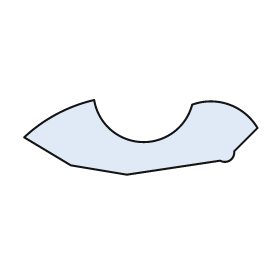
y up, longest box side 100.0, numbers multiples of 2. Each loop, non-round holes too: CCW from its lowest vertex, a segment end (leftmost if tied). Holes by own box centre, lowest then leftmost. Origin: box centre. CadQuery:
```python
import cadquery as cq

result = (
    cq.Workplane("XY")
    .moveTo(-6.0, -16.0)
    .lineTo(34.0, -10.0)
    .threePointArc((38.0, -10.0), (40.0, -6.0))
    .lineTo(50.0, 4.0)
    .threePointArc((38.0, 14.0), (22.0, 14.0))
    .threePointArc((0.0, -2.0), (-20.0, 16.0))
    .threePointArc((-36.0, 10.0), (-50.0, 0.0))
    .lineTo(-30.0, -12.0)
    .close()
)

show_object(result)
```